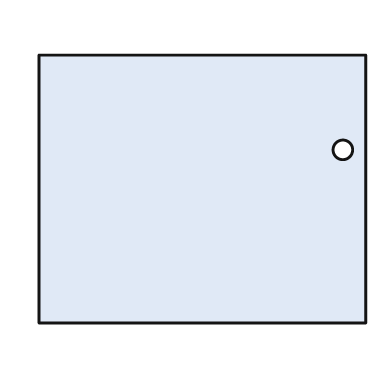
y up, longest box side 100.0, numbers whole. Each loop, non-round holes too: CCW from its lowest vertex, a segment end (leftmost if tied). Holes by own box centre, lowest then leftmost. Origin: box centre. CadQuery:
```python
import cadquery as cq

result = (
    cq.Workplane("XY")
    .moveTo(-50.0, -41.0)
    .lineTo(50.0, -41.0)
    .lineTo(50.0, 41.0)
    .lineTo(-50.0, 41.0)
    .close()
    .moveTo(43.0, 12.0)
    .circle(3.0)
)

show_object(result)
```